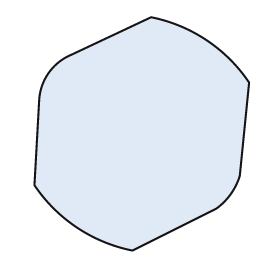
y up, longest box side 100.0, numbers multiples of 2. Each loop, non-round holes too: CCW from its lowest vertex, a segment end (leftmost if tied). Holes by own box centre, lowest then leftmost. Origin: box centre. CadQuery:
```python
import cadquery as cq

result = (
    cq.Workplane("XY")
    .moveTo(-4.0, -50.0)
    .lineTo(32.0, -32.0)
    .threePointArc((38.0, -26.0), (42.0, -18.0))
    .lineTo(46.0, 22.0)
    .threePointArc((28.0, 40.0), (4.0, 50.0))
    .lineTo(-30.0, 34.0)
    .threePointArc((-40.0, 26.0), (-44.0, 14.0))
    .lineTo(-46.0, -22.0)
    .threePointArc((-28.0, -40.0), (-4.0, -50.0))
    .close()
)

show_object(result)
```